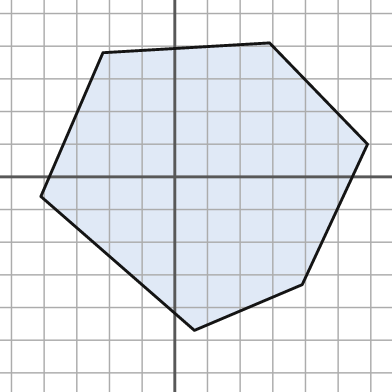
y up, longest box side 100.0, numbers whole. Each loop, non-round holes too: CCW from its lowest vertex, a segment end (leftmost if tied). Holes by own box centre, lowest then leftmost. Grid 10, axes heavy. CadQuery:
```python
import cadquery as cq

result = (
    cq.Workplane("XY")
    .moveTo(6.0, -47.0)
    .lineTo(39.0, -33.0)
    .lineTo(59.0, 10.0)
    .lineTo(29.0, 41.0)
    .lineTo(-22.0, 38.0)
    .lineTo(-41.0, -6.0)
    .close()
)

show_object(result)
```